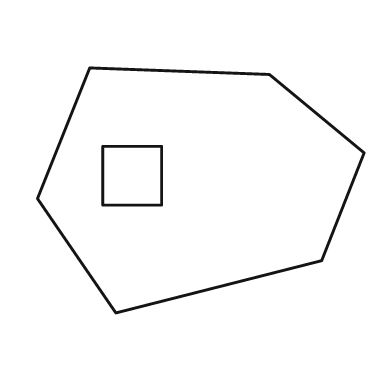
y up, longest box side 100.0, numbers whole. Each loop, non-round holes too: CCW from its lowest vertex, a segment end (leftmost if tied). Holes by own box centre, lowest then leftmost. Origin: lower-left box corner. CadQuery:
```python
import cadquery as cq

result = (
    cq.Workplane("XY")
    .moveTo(24.0, 0.0)
    .lineTo(87.0, 16.0)
    .lineTo(100.0, 49.0)
    .lineTo(71.0, 73.0)
    .lineTo(16.0, 75.0)
    .lineTo(0.0, 35.0)
    .close()
    .moveTo(20.0, 33.0)
    .lineTo(38.0, 33.0)
    .lineTo(38.0, 51.0)
    .lineTo(20.0, 51.0)
    .close()
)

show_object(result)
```